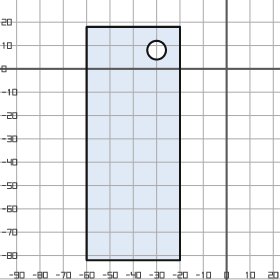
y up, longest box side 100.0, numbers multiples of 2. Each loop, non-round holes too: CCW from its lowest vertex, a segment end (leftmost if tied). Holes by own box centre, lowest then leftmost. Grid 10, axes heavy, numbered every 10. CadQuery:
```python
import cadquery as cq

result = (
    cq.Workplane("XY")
    .moveTo(-60.0, -82.0)
    .lineTo(-20.0, -82.0)
    .lineTo(-20.0, 18.0)
    .lineTo(-60.0, 18.0)
    .close()
    .moveTo(-30.0, 8.0)
    .circle(4.0)
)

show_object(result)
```